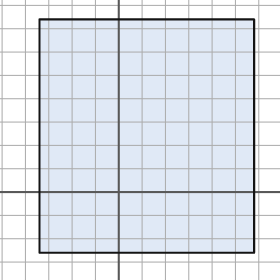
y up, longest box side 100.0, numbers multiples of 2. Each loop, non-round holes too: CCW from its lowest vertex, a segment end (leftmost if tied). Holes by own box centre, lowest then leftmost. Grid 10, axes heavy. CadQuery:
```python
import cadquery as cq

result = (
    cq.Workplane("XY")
    .moveTo(-34.0, -26.0)
    .lineTo(58.0, -26.0)
    .lineTo(58.0, 74.0)
    .lineTo(-34.0, 74.0)
    .close()
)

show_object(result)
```